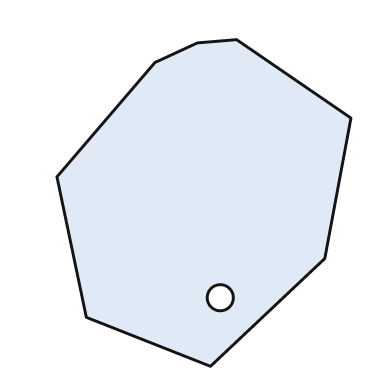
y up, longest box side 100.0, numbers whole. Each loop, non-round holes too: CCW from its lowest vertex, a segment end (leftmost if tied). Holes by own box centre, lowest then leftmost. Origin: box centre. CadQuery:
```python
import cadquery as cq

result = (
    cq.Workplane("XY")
    .moveTo(2.0, -50.0)
    .lineTo(37.0, -17.0)
    .lineTo(45.0, 26.0)
    .lineTo(10.0, 50.0)
    .lineTo(-2.0, 49.0)
    .lineTo(-15.0, 43.0)
    .lineTo(-45.0, 8.0)
    .lineTo(-36.0, -35.0)
    .close()
    .moveTo(5.0, -29.0)
    .circle(4.0)
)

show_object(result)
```